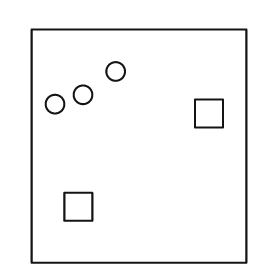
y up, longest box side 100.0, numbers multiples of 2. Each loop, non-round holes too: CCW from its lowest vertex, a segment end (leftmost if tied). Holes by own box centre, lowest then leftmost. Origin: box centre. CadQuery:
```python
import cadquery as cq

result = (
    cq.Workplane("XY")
    .moveTo(-46.0, -50.0)
    .lineTo(46.0, -50.0)
    .lineTo(46.0, 50.0)
    .lineTo(-46.0, 50.0)
    .close()
    .moveTo(-32.0, -32.0)
    .lineTo(-20.0, -32.0)
    .lineTo(-20.0, -20.0)
    .lineTo(-32.0, -20.0)
    .close()
    .moveTo(24.0, 8.0)
    .lineTo(36.0, 8.0)
    .lineTo(36.0, 20.0)
    .lineTo(24.0, 20.0)
    .close()
    .moveTo(-36.0, 18.0)
    .circle(4.0)
    .moveTo(-24.0, 22.0)
    .circle(4.0)
    .moveTo(-10.0, 32.0)
    .circle(4.0)
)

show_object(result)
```